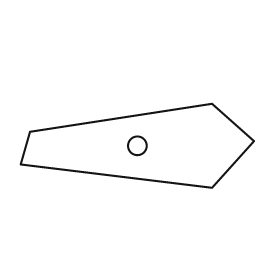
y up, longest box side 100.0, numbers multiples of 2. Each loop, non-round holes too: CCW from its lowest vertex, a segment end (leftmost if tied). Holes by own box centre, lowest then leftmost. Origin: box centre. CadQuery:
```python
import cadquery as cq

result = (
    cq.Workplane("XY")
    .moveTo(32.0, -18.0)
    .lineTo(50.0, 2.0)
    .lineTo(32.0, 18.0)
    .lineTo(-46.0, 6.0)
    .lineTo(-50.0, -8.0)
    .close()
    .moveTo(0.0, 0.0)
    .circle(4.0)
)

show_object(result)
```